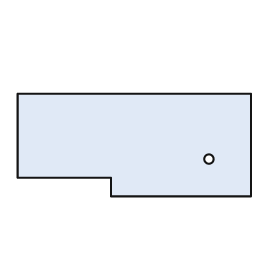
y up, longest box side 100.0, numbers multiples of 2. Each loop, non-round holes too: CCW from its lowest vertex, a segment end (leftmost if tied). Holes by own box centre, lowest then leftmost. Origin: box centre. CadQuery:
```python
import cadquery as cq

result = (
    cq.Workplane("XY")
    .moveTo(-10.0, -22.0)
    .lineTo(50.0, -22.0)
    .lineTo(50.0, 22.0)
    .lineTo(-50.0, 22.0)
    .lineTo(-50.0, -14.0)
    .lineTo(-10.0, -14.0)
    .close()
    .moveTo(32.0, -6.0)
    .circle(2.0)
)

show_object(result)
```